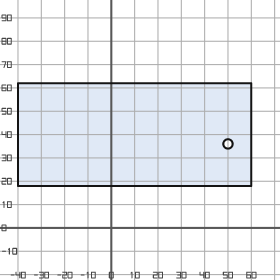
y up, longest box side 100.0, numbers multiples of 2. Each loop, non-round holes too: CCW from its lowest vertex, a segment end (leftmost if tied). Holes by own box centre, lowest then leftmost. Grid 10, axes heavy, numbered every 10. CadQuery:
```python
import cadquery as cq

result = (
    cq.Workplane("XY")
    .moveTo(-40.0, 18.0)
    .lineTo(60.0, 18.0)
    .lineTo(60.0, 62.0)
    .lineTo(-40.0, 62.0)
    .close()
    .moveTo(50.0, 36.0)
    .circle(2.0)
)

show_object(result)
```